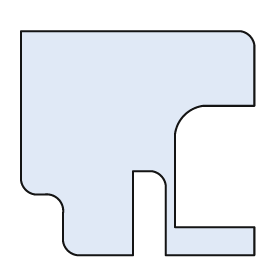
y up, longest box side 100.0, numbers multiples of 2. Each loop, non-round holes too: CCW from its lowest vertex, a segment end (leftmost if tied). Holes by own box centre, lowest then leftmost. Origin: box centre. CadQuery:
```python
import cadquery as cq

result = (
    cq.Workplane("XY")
    .moveTo(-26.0, -48.0)
    .lineTo(-2.0, -48.0)
    .lineTo(-2.0, -12.0)
    .lineTo(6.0, -12.0)
    .threePointArc((10.0, -14.0), (12.0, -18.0))
    .lineTo(12.0, -48.0)
    .lineTo(50.0, -48.0)
    .lineTo(50.0, -36.0)
    .lineTo(16.0, -36.0)
    .lineTo(16.0, 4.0)
    .threePointArc((20.0, 12.0), (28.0, 16.0))
    .lineTo(50.0, 16.0)
    .lineTo(50.0, 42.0)
    .threePointArc((48.0, 46.0), (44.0, 48.0))
    .lineTo(-50.0, 48.0)
    .lineTo(-50.0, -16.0)
    .threePointArc((-48.0, -20.0), (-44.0, -22.0))
    .lineTo(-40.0, -22.0)
    .threePointArc((-34.0, -24.0), (-32.0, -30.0))
    .lineTo(-32.0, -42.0)
    .threePointArc((-30.0, -46.0), (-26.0, -48.0))
    .close()
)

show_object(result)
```